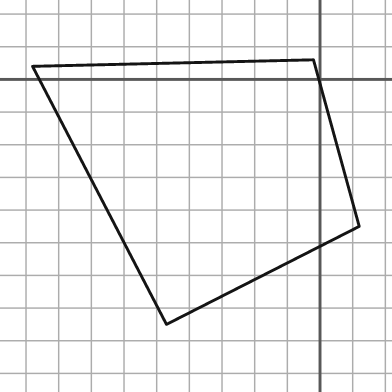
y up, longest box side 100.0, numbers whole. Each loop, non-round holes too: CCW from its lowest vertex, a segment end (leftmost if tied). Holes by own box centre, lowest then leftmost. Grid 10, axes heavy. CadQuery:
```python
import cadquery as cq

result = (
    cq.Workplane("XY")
    .moveTo(-47.0, -75.0)
    .lineTo(12.0, -45.0)
    .lineTo(-2.0, 6.0)
    .lineTo(-88.0, 4.0)
    .close()
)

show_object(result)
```